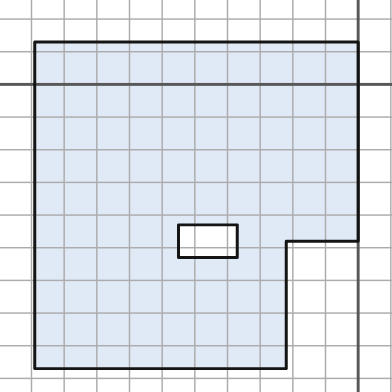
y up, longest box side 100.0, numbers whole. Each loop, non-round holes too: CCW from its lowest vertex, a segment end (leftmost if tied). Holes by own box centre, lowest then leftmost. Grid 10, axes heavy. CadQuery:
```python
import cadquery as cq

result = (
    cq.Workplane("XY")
    .moveTo(-99.0, -87.0)
    .lineTo(-22.0, -87.0)
    .lineTo(-22.0, -48.0)
    .lineTo(0.0, -48.0)
    .lineTo(0.0, 13.0)
    .lineTo(-99.0, 13.0)
    .close()
    .moveTo(-55.0, -53.0)
    .lineTo(-37.0, -53.0)
    .lineTo(-37.0, -43.0)
    .lineTo(-55.0, -43.0)
    .close()
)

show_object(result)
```